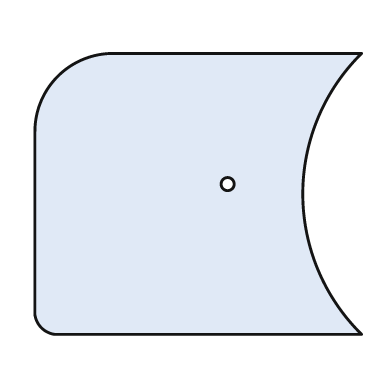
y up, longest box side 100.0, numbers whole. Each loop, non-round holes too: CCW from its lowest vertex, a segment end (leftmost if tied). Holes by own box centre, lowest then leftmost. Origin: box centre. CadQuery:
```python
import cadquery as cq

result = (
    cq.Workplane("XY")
    .moveTo(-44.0, -43.0)
    .lineTo(50.0, -43.0)
    .threePointArc((32.0, 0.0), (50.0, 43.0))
    .lineTo(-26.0, 43.0)
    .threePointArc((-43.0, 36.0), (-50.0, 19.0))
    .lineTo(-50.0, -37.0)
    .threePointArc((-48.0, -41.0), (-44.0, -43.0))
    .close()
    .moveTo(9.0, 3.0)
    .circle(2.0)
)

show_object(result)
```